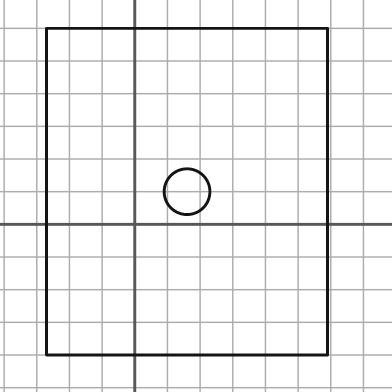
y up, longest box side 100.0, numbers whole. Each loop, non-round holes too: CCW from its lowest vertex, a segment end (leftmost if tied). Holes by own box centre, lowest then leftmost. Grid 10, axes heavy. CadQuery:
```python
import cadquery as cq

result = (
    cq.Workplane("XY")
    .moveTo(-27.0, -40.0)
    .lineTo(59.0, -40.0)
    .lineTo(59.0, 60.0)
    .lineTo(-27.0, 60.0)
    .close()
    .moveTo(16.0, 10.0)
    .circle(7.0)
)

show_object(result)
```